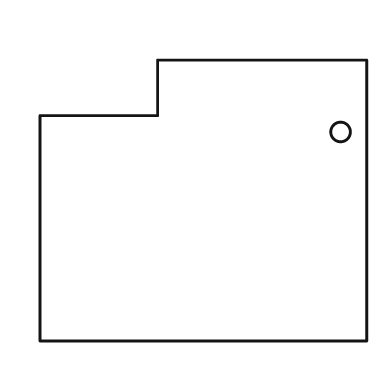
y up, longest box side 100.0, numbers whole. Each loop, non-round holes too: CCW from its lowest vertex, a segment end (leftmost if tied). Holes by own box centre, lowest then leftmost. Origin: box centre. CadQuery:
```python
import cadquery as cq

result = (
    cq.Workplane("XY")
    .moveTo(-50.0, -43.0)
    .lineTo(50.0, -43.0)
    .lineTo(50.0, 43.0)
    .lineTo(-14.0, 43.0)
    .lineTo(-14.0, 26.0)
    .lineTo(-50.0, 26.0)
    .close()
    .moveTo(42.0, 21.0)
    .circle(3.0)
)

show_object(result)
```